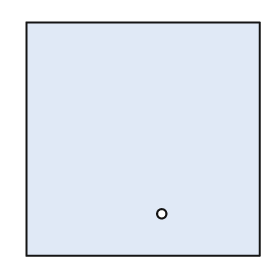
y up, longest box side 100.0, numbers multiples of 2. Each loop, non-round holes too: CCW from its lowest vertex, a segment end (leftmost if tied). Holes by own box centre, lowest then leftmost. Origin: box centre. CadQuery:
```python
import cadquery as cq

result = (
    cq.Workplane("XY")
    .moveTo(-50.0, -50.0)
    .lineTo(50.0, -50.0)
    .lineTo(50.0, 50.0)
    .lineTo(-50.0, 50.0)
    .close()
    .moveTo(8.0, -32.0)
    .circle(2.0)
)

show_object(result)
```